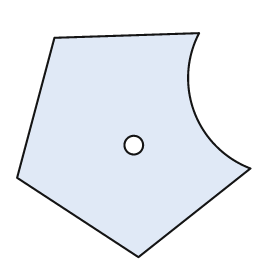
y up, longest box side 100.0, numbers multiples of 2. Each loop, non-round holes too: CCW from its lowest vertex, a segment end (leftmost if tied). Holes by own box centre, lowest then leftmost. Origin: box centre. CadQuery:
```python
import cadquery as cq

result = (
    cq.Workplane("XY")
    .moveTo(2.0, -48.0)
    .lineTo(50.0, -10.0)
    .threePointArc((26.0, 14.0), (28.0, 48.0))
    .lineTo(-34.0, 46.0)
    .lineTo(-50.0, -14.0)
    .close()
    .moveTo(0.0, 0.0)
    .circle(4.0)
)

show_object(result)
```